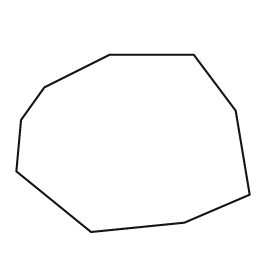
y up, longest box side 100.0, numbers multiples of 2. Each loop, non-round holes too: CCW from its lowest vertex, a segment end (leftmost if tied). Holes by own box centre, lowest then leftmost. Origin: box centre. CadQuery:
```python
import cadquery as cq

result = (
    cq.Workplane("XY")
    .moveTo(-18.0, -38.0)
    .lineTo(22.0, -34.0)
    .lineTo(50.0, -22.0)
    .lineTo(44.0, 14.0)
    .lineTo(26.0, 38.0)
    .lineTo(-10.0, 38.0)
    .lineTo(-38.0, 24.0)
    .lineTo(-48.0, 10.0)
    .lineTo(-50.0, -12.0)
    .close()
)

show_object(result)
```